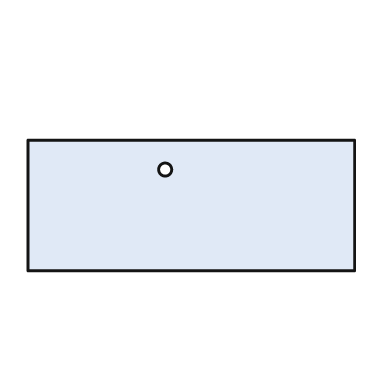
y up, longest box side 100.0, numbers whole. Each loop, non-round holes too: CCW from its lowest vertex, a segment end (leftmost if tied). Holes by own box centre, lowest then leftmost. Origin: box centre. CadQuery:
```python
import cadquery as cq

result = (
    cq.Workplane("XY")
    .moveTo(-50.0, -20.0)
    .lineTo(50.0, -20.0)
    .lineTo(50.0, 20.0)
    .lineTo(-50.0, 20.0)
    .close()
    .moveTo(-8.0, 11.0)
    .circle(2.0)
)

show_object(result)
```